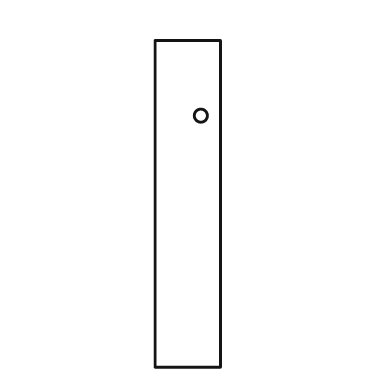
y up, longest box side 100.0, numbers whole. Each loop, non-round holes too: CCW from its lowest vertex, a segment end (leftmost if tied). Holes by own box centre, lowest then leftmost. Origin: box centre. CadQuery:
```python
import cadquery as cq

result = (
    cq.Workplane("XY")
    .moveTo(-10.0, -50.0)
    .lineTo(10.0, -50.0)
    .lineTo(10.0, 50.0)
    .lineTo(-10.0, 50.0)
    .close()
    .moveTo(4.0, 27.0)
    .circle(2.0)
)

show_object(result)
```